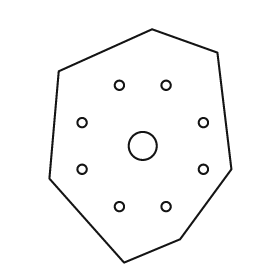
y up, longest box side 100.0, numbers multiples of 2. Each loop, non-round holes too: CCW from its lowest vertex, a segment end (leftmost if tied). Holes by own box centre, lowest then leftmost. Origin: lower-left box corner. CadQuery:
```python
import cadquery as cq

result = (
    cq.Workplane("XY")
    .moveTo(32.0, 0.0)
    .lineTo(56.0, 10.0)
    .lineTo(78.0, 40.0)
    .lineTo(72.0, 90.0)
    .lineTo(44.0, 100.0)
    .lineTo(4.0, 82.0)
    .lineTo(0.0, 36.0)
    .close()
    .moveTo(30.0, 24.0)
    .circle(2.0)
    .moveTo(50.0, 24.0)
    .circle(2.0)
    .moveTo(14.0, 40.0)
    .circle(2.0)
    .moveTo(66.0, 40.0)
    .circle(2.0)
    .moveTo(40.0, 50.0)
    .circle(6.0)
    .moveTo(14.0, 60.0)
    .circle(2.0)
    .moveTo(66.0, 60.0)
    .circle(2.0)
    .moveTo(30.0, 76.0)
    .circle(2.0)
    .moveTo(50.0, 76.0)
    .circle(2.0)
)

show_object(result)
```